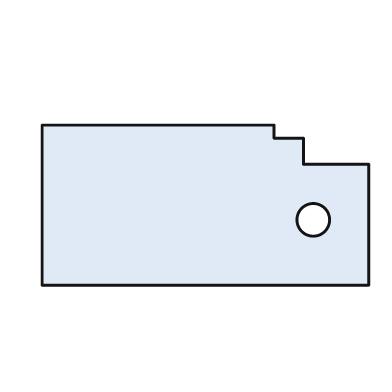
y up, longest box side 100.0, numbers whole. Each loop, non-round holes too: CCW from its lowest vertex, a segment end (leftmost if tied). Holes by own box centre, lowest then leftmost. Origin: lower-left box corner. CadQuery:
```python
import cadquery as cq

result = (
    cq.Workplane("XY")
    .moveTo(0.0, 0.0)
    .lineTo(100.0, 0.0)
    .lineTo(100.0, 37.0)
    .lineTo(80.0, 37.0)
    .lineTo(80.0, 45.0)
    .lineTo(71.0, 45.0)
    .lineTo(71.0, 49.0)
    .lineTo(0.0, 49.0)
    .close()
    .moveTo(83.0, 20.0)
    .circle(5.0)
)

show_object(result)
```